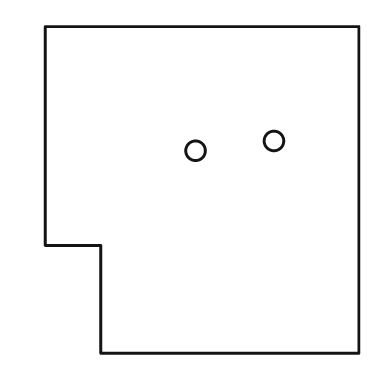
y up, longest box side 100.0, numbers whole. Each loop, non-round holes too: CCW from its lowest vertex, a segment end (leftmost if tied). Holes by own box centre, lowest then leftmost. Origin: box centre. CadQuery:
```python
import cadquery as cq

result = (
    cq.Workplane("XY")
    .moveTo(-31.0, -50.0)
    .lineTo(48.0, -50.0)
    .lineTo(48.0, 50.0)
    .lineTo(-48.0, 50.0)
    .lineTo(-48.0, -17.0)
    .lineTo(-31.0, -17.0)
    .close()
    .moveTo(-2.0, 12.0)
    .circle(3.0)
    .moveTo(22.0, 15.0)
    .circle(3.0)
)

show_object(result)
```